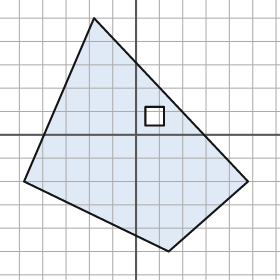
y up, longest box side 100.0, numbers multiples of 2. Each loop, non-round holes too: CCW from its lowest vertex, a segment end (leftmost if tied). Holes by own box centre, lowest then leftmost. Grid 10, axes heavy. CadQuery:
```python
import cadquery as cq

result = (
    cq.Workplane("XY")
    .moveTo(14.0, -50.0)
    .lineTo(48.0, -20.0)
    .lineTo(-18.0, 50.0)
    .lineTo(-48.0, -20.0)
    .close()
    .moveTo(4.0, 4.0)
    .lineTo(12.0, 4.0)
    .lineTo(12.0, 12.0)
    .lineTo(4.0, 12.0)
    .close()
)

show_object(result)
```